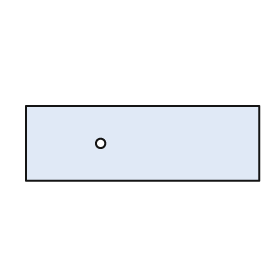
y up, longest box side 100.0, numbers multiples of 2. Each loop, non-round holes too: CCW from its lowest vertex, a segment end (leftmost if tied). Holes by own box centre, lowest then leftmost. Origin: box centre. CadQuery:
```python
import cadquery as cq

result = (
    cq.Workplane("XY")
    .moveTo(-50.0, -16.0)
    .lineTo(50.0, -16.0)
    .lineTo(50.0, 16.0)
    .lineTo(-50.0, 16.0)
    .close()
    .moveTo(-18.0, 0.0)
    .circle(2.0)
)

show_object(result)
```